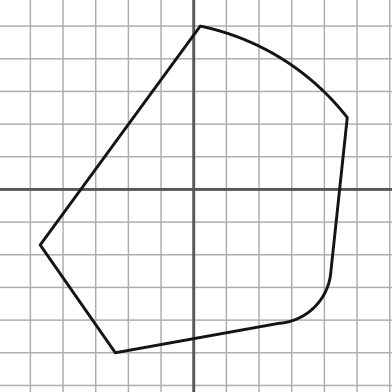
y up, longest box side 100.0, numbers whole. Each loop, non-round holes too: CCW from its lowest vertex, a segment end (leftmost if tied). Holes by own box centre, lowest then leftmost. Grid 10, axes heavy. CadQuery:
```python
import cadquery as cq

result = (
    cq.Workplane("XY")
    .moveTo(-24.0, -50.0)
    .lineTo(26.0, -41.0)
    .threePointArc((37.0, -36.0), (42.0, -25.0))
    .lineTo(47.0, 22.0)
    .threePointArc((27.0, 40.0), (2.0, 50.0))
    .lineTo(-47.0, -17.0)
    .close()
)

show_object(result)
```